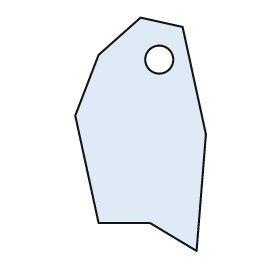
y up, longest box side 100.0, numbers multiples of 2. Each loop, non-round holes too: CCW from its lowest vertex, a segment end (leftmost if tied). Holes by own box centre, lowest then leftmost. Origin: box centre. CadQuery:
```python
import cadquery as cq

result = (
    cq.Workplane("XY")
    .moveTo(24.0, -50.0)
    .lineTo(28.0, 0.0)
    .lineTo(18.0, 46.0)
    .lineTo(0.0, 50.0)
    .lineTo(-18.0, 34.0)
    .lineTo(-28.0, 8.0)
    .lineTo(-18.0, -38.0)
    .lineTo(4.0, -38.0)
    .close()
    .moveTo(8.0, 32.0)
    .circle(6.0)
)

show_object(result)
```